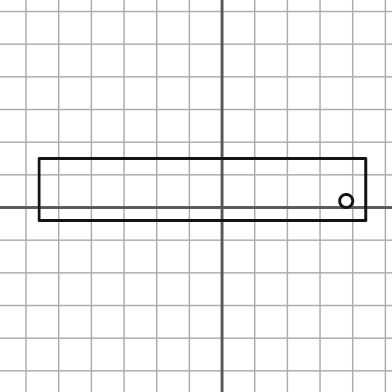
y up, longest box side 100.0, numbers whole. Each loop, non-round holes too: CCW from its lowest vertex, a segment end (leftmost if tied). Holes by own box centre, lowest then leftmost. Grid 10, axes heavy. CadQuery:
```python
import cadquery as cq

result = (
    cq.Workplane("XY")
    .moveTo(-56.0, -4.0)
    .lineTo(44.0, -4.0)
    .lineTo(44.0, 15.0)
    .lineTo(-56.0, 15.0)
    .close()
    .moveTo(38.0, 2.0)
    .circle(2.0)
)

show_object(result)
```